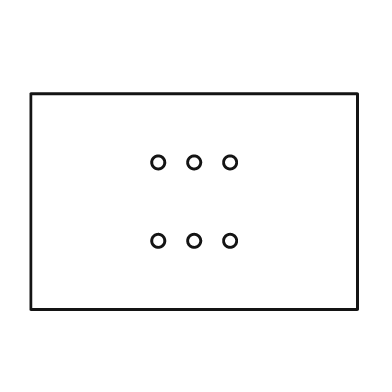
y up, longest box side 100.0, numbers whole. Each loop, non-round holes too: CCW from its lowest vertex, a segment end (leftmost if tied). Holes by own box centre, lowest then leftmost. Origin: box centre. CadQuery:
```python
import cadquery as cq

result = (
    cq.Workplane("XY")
    .moveTo(-50.0, -33.0)
    .lineTo(50.0, -33.0)
    .lineTo(50.0, 33.0)
    .lineTo(-50.0, 33.0)
    .close()
    .moveTo(-11.0, -12.0)
    .circle(2.0)
    .moveTo(0.0, -12.0)
    .circle(2.0)
    .moveTo(11.0, -12.0)
    .circle(2.0)
    .moveTo(-11.0, 12.0)
    .circle(2.0)
    .moveTo(0.0, 12.0)
    .circle(2.0)
    .moveTo(11.0, 12.0)
    .circle(2.0)
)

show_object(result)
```